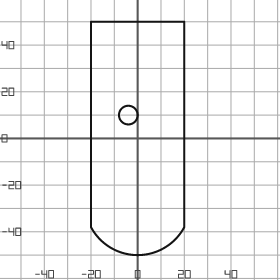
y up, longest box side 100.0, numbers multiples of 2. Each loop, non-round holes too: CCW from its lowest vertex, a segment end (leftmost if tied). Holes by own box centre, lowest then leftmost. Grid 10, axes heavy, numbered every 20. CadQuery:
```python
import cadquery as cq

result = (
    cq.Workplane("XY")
    .moveTo(-20.0, -38.0)
    .threePointArc((0.0, -50.0), (20.0, -38.0))
    .lineTo(20.0, 50.0)
    .lineTo(-20.0, 50.0)
    .close()
    .moveTo(-4.0, 10.0)
    .circle(4.0)
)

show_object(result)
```